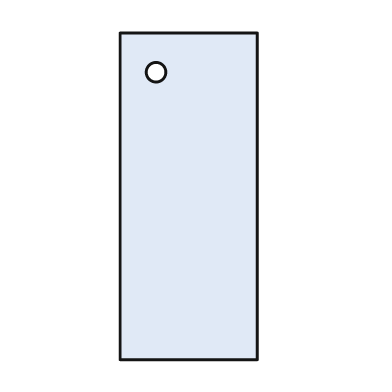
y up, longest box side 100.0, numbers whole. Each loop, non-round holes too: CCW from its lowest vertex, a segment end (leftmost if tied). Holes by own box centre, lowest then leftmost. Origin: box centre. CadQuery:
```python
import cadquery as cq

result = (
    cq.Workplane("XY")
    .moveTo(-21.0, -50.0)
    .lineTo(21.0, -50.0)
    .lineTo(21.0, 50.0)
    .lineTo(-21.0, 50.0)
    .close()
    .moveTo(-10.0, 38.0)
    .circle(3.0)
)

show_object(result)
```